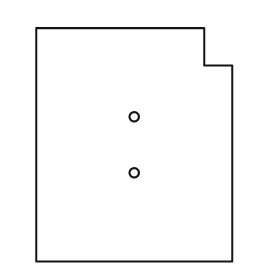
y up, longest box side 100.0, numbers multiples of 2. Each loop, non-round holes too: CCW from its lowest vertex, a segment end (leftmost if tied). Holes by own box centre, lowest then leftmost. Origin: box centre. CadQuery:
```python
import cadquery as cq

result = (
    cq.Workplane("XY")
    .moveTo(-42.0, -50.0)
    .lineTo(42.0, -50.0)
    .lineTo(42.0, 34.0)
    .lineTo(30.0, 34.0)
    .lineTo(30.0, 50.0)
    .lineTo(-42.0, 50.0)
    .close()
    .moveTo(0.0, -12.0)
    .circle(2.0)
    .moveTo(0.0, 12.0)
    .circle(2.0)
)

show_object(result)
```